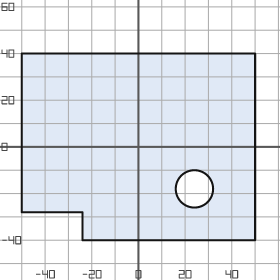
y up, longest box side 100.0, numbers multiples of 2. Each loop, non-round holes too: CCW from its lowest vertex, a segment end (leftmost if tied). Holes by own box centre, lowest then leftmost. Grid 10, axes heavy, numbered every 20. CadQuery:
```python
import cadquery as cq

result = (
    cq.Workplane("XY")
    .moveTo(-24.0, -40.0)
    .lineTo(50.0, -40.0)
    .lineTo(50.0, 40.0)
    .lineTo(-50.0, 40.0)
    .lineTo(-50.0, -28.0)
    .lineTo(-24.0, -28.0)
    .close()
    .moveTo(24.0, -18.0)
    .circle(8.0)
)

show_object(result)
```